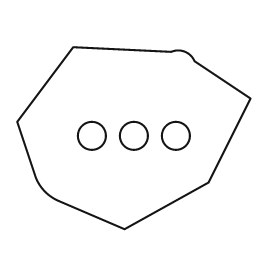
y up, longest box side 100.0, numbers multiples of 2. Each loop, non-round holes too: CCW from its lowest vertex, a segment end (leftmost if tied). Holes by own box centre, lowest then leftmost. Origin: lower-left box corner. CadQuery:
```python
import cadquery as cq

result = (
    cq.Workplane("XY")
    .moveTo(46.0, 0.0)
    .lineTo(82.0, 20.0)
    .lineTo(100.0, 56.0)
    .lineTo(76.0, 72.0)
    .threePointArc((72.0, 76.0), (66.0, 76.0))
    .lineTo(24.0, 78.0)
    .lineTo(0.0, 46.0)
    .lineTo(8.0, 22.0)
    .threePointArc((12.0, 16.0), (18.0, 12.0))
    .close()
    .moveTo(32.0, 40.0)
    .circle(6.0)
    .moveTo(50.0, 40.0)
    .circle(6.0)
    .moveTo(68.0, 40.0)
    .circle(6.0)
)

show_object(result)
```